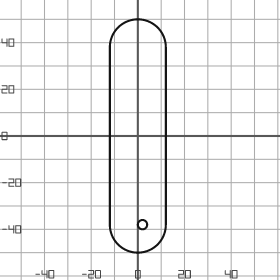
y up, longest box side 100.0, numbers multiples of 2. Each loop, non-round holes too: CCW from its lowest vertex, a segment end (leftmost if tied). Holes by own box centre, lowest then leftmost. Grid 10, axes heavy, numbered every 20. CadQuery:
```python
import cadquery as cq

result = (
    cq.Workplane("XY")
    .moveTo(-12.0, -38.0)
    .threePointArc((0.0, -50.0), (12.0, -38.0))
    .lineTo(12.0, 38.0)
    .threePointArc((0.0, 50.0), (-12.0, 38.0))
    .close()
    .moveTo(2.0, -38.0)
    .circle(2.0)
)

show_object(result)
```